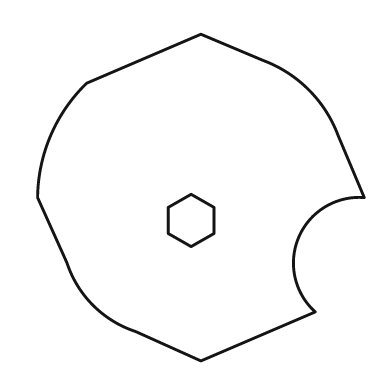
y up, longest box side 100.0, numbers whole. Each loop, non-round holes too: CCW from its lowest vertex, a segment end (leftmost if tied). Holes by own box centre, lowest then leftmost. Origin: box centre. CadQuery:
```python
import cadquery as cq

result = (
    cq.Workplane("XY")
    .moveTo(0.0, -50.0)
    .lineTo(35.0, -35.0)
    .threePointArc((30.0, -12.0), (50.0, 0.0))
    .lineTo(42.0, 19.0)
    .threePointArc((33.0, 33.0), (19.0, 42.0))
    .lineTo(0.0, 50.0)
    .lineTo(-35.0, 35.0)
    .threePointArc((-46.0, 19.0), (-50.0, 0.0))
    .lineTo(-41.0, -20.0)
    .threePointArc((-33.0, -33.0), (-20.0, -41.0))
    .close()
    .moveTo(-3.0, -15.0)
    .lineTo(4.0, -11.0)
    .lineTo(4.0, -3.0)
    .lineTo(-3.0, 1.0)
    .lineTo(-10.0, -3.0)
    .lineTo(-10.0, -11.0)
    .close()
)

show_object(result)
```